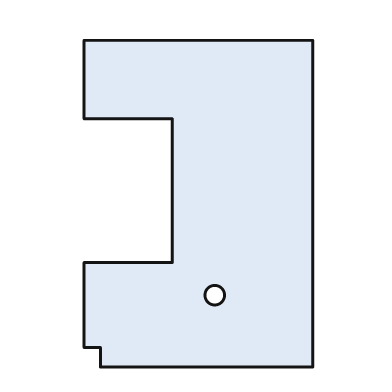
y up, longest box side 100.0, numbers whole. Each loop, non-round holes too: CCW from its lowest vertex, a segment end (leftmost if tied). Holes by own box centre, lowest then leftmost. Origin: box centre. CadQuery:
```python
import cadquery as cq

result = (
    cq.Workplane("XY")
    .moveTo(-30.0, -50.0)
    .lineTo(35.0, -50.0)
    .lineTo(35.0, 50.0)
    .lineTo(-35.0, 50.0)
    .lineTo(-35.0, 26.0)
    .lineTo(-8.0, 26.0)
    .lineTo(-8.0, -18.0)
    .lineTo(-35.0, -18.0)
    .lineTo(-35.0, -44.0)
    .lineTo(-30.0, -44.0)
    .close()
    .moveTo(5.0, -28.0)
    .circle(3.0)
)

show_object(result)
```